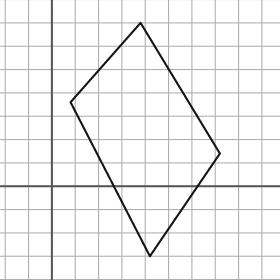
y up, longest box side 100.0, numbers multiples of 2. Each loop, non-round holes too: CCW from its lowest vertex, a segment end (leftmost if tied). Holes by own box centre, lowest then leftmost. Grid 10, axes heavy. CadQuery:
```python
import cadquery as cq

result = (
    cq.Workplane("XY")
    .moveTo(42.0, -30.0)
    .lineTo(72.0, 14.0)
    .lineTo(38.0, 70.0)
    .lineTo(8.0, 36.0)
    .close()
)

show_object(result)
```